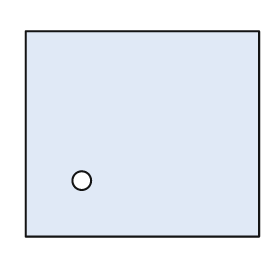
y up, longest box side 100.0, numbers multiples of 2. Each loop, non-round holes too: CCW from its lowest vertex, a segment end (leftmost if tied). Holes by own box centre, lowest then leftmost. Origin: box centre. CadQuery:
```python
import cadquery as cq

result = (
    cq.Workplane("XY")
    .moveTo(-50.0, -44.0)
    .lineTo(50.0, -44.0)
    .lineTo(50.0, 44.0)
    .lineTo(-50.0, 44.0)
    .close()
    .moveTo(-26.0, -20.0)
    .circle(4.0)
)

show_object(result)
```